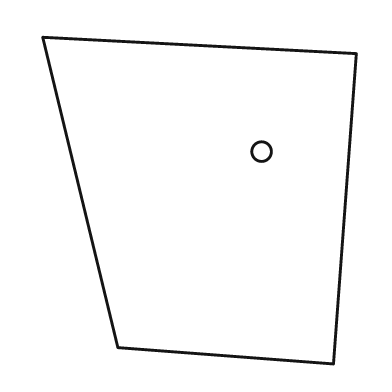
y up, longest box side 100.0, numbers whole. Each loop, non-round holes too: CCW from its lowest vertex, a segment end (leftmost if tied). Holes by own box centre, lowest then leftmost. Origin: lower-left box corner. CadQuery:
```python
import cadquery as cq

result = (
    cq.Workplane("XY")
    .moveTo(89.0, 0.0)
    .lineTo(96.0, 95.0)
    .lineTo(0.0, 100.0)
    .lineTo(23.0, 5.0)
    .close()
    .moveTo(67.0, 65.0)
    .circle(3.0)
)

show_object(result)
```